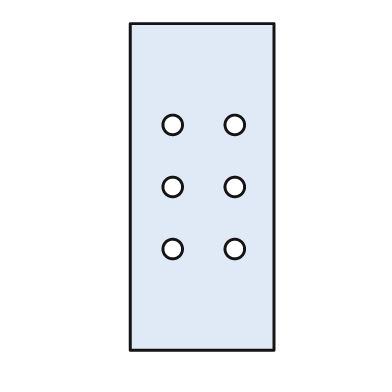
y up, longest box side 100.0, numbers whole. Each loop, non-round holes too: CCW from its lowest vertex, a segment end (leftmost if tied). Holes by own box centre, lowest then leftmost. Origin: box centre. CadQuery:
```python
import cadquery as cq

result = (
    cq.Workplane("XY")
    .moveTo(-22.0, -50.0)
    .lineTo(22.0, -50.0)
    .lineTo(22.0, 50.0)
    .lineTo(-22.0, 50.0)
    .close()
    .moveTo(-9.0, -19.0)
    .circle(3.0)
    .moveTo(10.0, -19.0)
    .circle(3.0)
    .moveTo(-9.0, 0.0)
    .circle(3.0)
    .moveTo(10.0, 0.0)
    .circle(3.0)
    .moveTo(-9.0, 19.0)
    .circle(3.0)
    .moveTo(10.0, 19.0)
    .circle(3.0)
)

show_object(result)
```